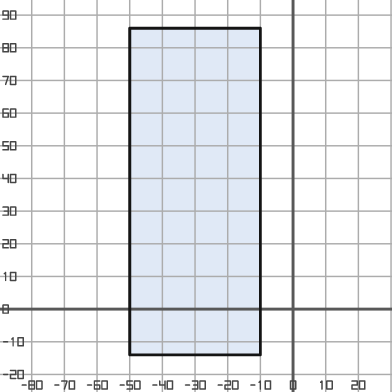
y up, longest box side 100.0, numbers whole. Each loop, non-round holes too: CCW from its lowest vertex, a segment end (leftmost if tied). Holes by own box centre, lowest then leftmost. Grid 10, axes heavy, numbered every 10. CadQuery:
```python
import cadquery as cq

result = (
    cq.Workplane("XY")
    .moveTo(-50.0, -14.0)
    .lineTo(-10.0, -14.0)
    .lineTo(-10.0, 86.0)
    .lineTo(-50.0, 86.0)
    .close()
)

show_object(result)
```